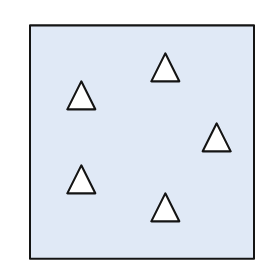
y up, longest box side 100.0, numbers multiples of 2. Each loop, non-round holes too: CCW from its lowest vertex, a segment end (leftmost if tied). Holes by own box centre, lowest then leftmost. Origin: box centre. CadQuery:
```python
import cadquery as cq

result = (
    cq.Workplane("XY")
    .moveTo(-48.0, -50.0)
    .lineTo(48.0, -50.0)
    .lineTo(48.0, 50.0)
    .lineTo(-48.0, 50.0)
    .close()
    .moveTo(4.0, -34.0)
    .lineTo(16.0, -34.0)
    .lineTo(10.0, -22.0)
    .close()
    .moveTo(-32.0, -22.0)
    .lineTo(-20.0, -22.0)
    .lineTo(-26.0, -10.0)
    .close()
    .moveTo(26.0, -4.0)
    .lineTo(38.0, -4.0)
    .lineTo(32.0, 8.0)
    .close()
    .moveTo(-32.0, 14.0)
    .lineTo(-20.0, 14.0)
    .lineTo(-26.0, 26.0)
    .close()
    .moveTo(4.0, 26.0)
    .lineTo(16.0, 26.0)
    .lineTo(10.0, 38.0)
    .close()
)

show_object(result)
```